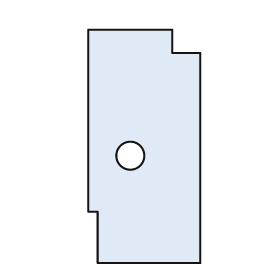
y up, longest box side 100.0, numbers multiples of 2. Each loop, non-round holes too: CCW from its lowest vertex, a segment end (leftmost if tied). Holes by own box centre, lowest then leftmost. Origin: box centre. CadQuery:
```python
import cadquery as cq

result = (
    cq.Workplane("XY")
    .moveTo(-20.0, -50.0)
    .lineTo(24.0, -50.0)
    .lineTo(24.0, 40.0)
    .lineTo(12.0, 40.0)
    .lineTo(12.0, 50.0)
    .lineTo(-24.0, 50.0)
    .lineTo(-24.0, -28.0)
    .lineTo(-20.0, -28.0)
    .close()
    .moveTo(-6.0, -4.0)
    .circle(6.0)
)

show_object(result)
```